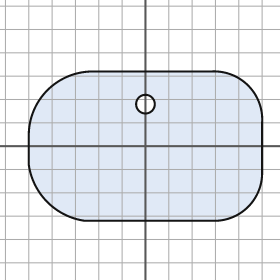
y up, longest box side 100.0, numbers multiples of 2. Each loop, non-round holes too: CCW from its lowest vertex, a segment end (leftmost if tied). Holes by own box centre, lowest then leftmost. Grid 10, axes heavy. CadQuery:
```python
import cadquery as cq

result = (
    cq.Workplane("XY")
    .moveTo(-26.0, -32.0)
    .lineTo(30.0, -32.0)
    .threePointArc((44.0, -26.0), (50.0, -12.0))
    .lineTo(50.0, 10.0)
    .threePointArc((44.0, 26.0), (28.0, 32.0))
    .lineTo(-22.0, 32.0)
    .threePointArc((-42.0, 24.0), (-50.0, 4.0))
    .lineTo(-50.0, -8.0)
    .threePointArc((-42.0, -24.0), (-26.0, -32.0))
    .close()
    .moveTo(0.0, 18.0)
    .circle(4.0)
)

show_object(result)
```